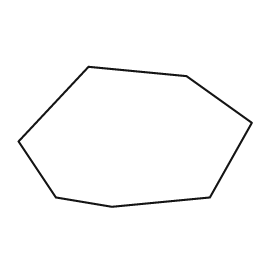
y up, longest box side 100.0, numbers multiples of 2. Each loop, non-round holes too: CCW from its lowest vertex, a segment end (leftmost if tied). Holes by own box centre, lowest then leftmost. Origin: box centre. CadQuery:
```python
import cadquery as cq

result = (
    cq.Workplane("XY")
    .moveTo(-10.0, -30.0)
    .lineTo(32.0, -26.0)
    .lineTo(50.0, 6.0)
    .lineTo(22.0, 26.0)
    .lineTo(-20.0, 30.0)
    .lineTo(-50.0, -2.0)
    .lineTo(-34.0, -26.0)
    .close()
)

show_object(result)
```